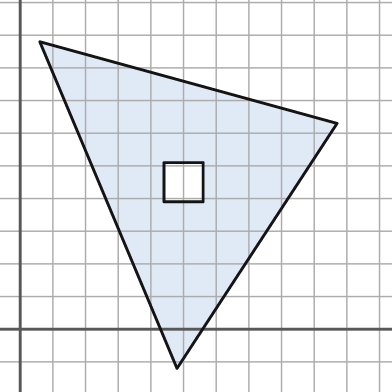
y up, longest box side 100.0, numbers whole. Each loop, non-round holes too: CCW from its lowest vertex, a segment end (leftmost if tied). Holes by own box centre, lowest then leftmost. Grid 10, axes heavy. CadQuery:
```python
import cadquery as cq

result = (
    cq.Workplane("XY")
    .moveTo(48.0, -12.0)
    .lineTo(97.0, 63.0)
    .lineTo(6.0, 88.0)
    .close()
    .moveTo(44.0, 39.0)
    .lineTo(56.0, 39.0)
    .lineTo(56.0, 51.0)
    .lineTo(44.0, 51.0)
    .close()
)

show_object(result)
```